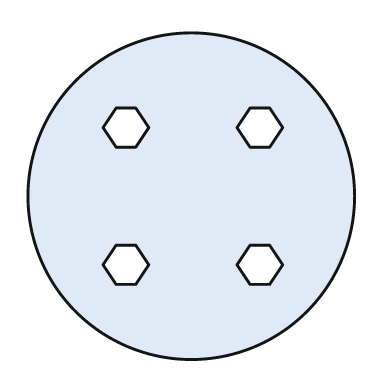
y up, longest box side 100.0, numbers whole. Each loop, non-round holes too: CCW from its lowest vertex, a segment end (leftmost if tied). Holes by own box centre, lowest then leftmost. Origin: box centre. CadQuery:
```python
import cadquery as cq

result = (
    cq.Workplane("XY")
    .moveTo(0.0, 0.0)
    .circle(50.0)
    .moveTo(-23.0, -27.0)
    .lineTo(-17.0, -27.0)
    .lineTo(-13.0, -21.0)
    .lineTo(-17.0, -15.0)
    .lineTo(-23.0, -15.0)
    .lineTo(-27.0, -21.0)
    .close()
    .moveTo(18.0, -27.0)
    .lineTo(24.0, -27.0)
    .lineTo(28.0, -21.0)
    .lineTo(24.0, -15.0)
    .lineTo(18.0, -15.0)
    .lineTo(14.0, -21.0)
    .close()
    .moveTo(-23.0, 15.0)
    .lineTo(-17.0, 15.0)
    .lineTo(-13.0, 21.0)
    .lineTo(-17.0, 27.0)
    .lineTo(-23.0, 27.0)
    .lineTo(-27.0, 21.0)
    .close()
    .moveTo(18.0, 15.0)
    .lineTo(24.0, 15.0)
    .lineTo(28.0, 21.0)
    .lineTo(24.0, 27.0)
    .lineTo(18.0, 27.0)
    .lineTo(14.0, 21.0)
    .close()
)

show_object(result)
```